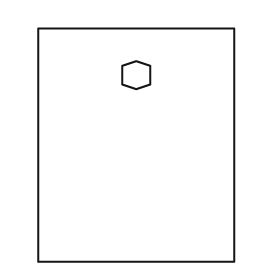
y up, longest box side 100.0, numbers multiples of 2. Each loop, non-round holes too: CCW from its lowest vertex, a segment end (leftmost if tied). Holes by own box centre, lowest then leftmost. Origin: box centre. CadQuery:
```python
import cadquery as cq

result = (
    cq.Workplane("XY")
    .moveTo(-42.0, -50.0)
    .lineTo(42.0, -50.0)
    .lineTo(42.0, 50.0)
    .lineTo(-42.0, 50.0)
    .close()
    .moveTo(0.0, 24.0)
    .lineTo(6.0, 26.0)
    .lineTo(6.0, 34.0)
    .lineTo(0.0, 36.0)
    .lineTo(-6.0, 34.0)
    .lineTo(-6.0, 26.0)
    .close()
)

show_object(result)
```